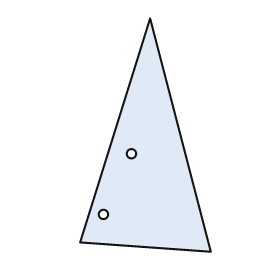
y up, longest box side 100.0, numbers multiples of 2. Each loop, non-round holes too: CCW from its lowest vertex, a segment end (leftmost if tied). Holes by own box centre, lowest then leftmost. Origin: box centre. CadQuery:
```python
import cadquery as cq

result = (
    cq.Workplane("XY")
    .moveTo(28.0, -50.0)
    .lineTo(2.0, 50.0)
    .lineTo(-28.0, -46.0)
    .close()
    .moveTo(-18.0, -34.0)
    .circle(2.0)
    .moveTo(-6.0, -8.0)
    .circle(2.0)
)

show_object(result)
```